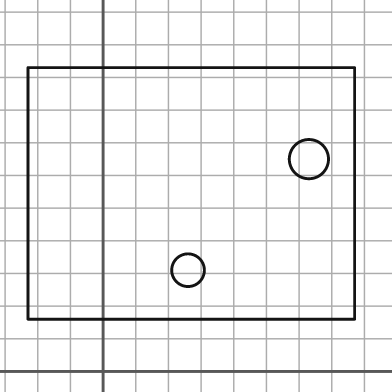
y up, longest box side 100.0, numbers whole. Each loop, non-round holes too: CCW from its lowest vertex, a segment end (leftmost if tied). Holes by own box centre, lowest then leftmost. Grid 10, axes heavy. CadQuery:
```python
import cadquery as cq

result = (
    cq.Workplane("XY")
    .moveTo(-23.0, 16.0)
    .lineTo(77.0, 16.0)
    .lineTo(77.0, 93.0)
    .lineTo(-23.0, 93.0)
    .close()
    .moveTo(26.0, 31.0)
    .circle(5.0)
    .moveTo(63.0, 65.0)
    .circle(6.0)
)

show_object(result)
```